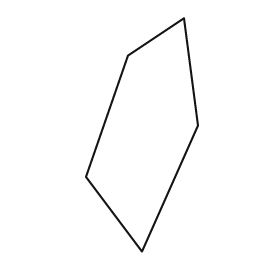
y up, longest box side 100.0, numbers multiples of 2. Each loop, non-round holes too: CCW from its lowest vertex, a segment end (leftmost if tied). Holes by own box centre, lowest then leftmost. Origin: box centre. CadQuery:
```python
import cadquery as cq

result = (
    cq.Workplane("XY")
    .moveTo(0.0, -50.0)
    .lineTo(24.0, 4.0)
    .lineTo(18.0, 50.0)
    .lineTo(-6.0, 34.0)
    .lineTo(-24.0, -18.0)
    .close()
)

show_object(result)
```